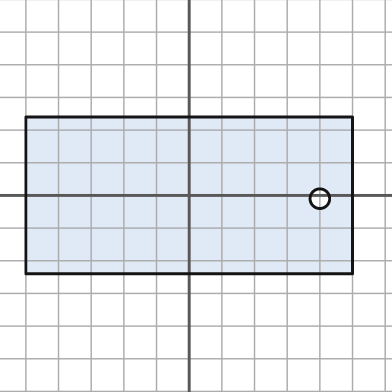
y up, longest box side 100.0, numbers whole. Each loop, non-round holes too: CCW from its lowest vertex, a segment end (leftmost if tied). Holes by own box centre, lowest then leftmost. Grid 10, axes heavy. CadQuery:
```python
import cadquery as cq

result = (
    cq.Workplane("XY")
    .moveTo(-50.0, -24.0)
    .lineTo(50.0, -24.0)
    .lineTo(50.0, 24.0)
    .lineTo(-50.0, 24.0)
    .close()
    .moveTo(40.0, -1.0)
    .circle(3.0)
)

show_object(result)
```